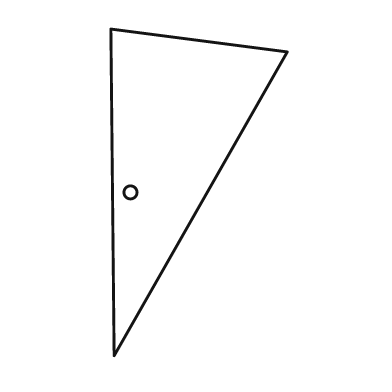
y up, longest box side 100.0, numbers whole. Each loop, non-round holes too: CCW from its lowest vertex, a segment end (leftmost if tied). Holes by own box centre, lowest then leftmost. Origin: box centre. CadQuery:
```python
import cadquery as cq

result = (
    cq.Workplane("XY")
    .moveTo(-26.0, -50.0)
    .lineTo(27.0, 43.0)
    .lineTo(-27.0, 50.0)
    .close()
    .moveTo(-21.0, 0.0)
    .circle(2.0)
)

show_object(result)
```